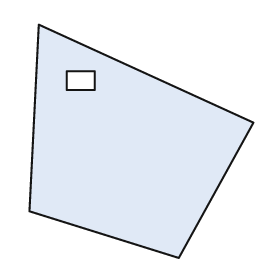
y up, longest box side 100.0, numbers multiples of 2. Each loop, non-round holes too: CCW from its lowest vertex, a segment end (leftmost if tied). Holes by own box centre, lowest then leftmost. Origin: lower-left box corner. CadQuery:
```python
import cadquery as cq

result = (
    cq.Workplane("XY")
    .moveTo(64.0, 0.0)
    .lineTo(96.0, 58.0)
    .lineTo(4.0, 100.0)
    .lineTo(0.0, 20.0)
    .close()
    .moveTo(16.0, 72.0)
    .lineTo(28.0, 72.0)
    .lineTo(28.0, 80.0)
    .lineTo(16.0, 80.0)
    .close()
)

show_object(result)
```